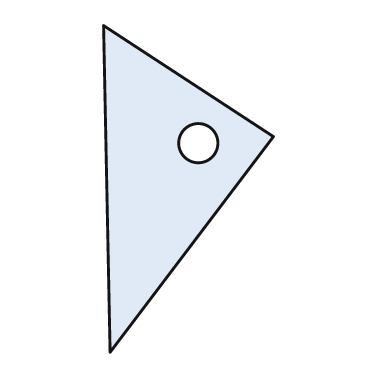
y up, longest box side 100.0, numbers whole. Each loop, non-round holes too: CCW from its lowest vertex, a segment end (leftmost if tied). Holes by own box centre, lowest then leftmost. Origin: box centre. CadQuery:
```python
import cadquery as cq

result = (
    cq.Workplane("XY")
    .moveTo(-24.0, -50.0)
    .lineTo(26.0, 16.0)
    .lineTo(-26.0, 50.0)
    .close()
    .moveTo(3.0, 14.0)
    .circle(6.0)
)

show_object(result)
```